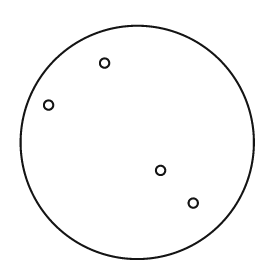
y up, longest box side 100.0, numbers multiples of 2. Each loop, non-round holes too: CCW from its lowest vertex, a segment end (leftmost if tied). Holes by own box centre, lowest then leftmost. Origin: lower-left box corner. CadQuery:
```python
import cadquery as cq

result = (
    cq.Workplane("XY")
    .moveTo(50.0, 50.0)
    .circle(50.0)
    .moveTo(74.0, 24.0)
    .circle(2.0)
    .moveTo(60.0, 38.0)
    .circle(2.0)
    .moveTo(12.0, 66.0)
    .circle(2.0)
    .moveTo(36.0, 84.0)
    .circle(2.0)
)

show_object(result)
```